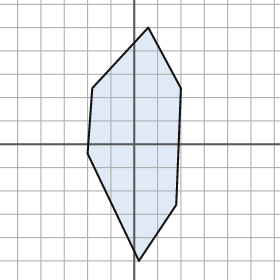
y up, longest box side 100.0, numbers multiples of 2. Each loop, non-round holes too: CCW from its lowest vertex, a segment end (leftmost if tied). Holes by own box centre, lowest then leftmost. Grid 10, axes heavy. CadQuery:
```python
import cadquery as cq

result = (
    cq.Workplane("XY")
    .moveTo(2.0, -50.0)
    .lineTo(18.0, -26.0)
    .lineTo(20.0, 24.0)
    .lineTo(6.0, 50.0)
    .lineTo(-18.0, 24.0)
    .lineTo(-20.0, -4.0)
    .close()
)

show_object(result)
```